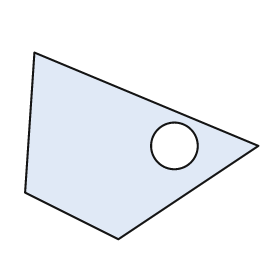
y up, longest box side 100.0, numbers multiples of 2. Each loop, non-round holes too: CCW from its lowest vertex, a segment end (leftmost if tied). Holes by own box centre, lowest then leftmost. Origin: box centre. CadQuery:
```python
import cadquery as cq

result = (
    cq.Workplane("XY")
    .moveTo(-10.0, -40.0)
    .lineTo(50.0, 0.0)
    .lineTo(-46.0, 40.0)
    .lineTo(-50.0, -20.0)
    .close()
    .moveTo(14.0, 0.0)
    .circle(10.0)
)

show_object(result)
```